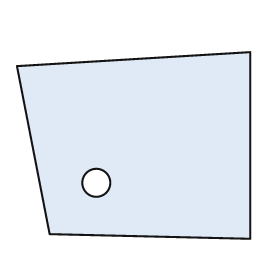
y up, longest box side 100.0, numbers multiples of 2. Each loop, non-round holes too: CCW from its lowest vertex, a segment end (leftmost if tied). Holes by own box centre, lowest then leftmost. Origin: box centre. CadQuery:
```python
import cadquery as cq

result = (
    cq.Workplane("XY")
    .moveTo(50.0, -40.0)
    .lineTo(50.0, 40.0)
    .lineTo(-50.0, 34.0)
    .lineTo(-36.0, -38.0)
    .close()
    .moveTo(-16.0, -16.0)
    .circle(6.0)
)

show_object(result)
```